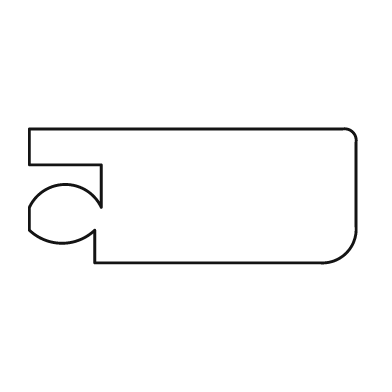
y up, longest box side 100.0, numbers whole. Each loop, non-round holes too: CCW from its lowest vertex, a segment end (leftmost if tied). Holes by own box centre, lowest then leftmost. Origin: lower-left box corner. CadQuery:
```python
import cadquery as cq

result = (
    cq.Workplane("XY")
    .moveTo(20.0, 0.0)
    .lineTo(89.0, 0.0)
    .threePointArc((97.0, 3.0), (100.0, 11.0))
    .lineTo(100.0, 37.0)
    .threePointArc((99.0, 40.0), (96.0, 41.0))
    .lineTo(0.0, 41.0)
    .lineTo(0.0, 30.0)
    .lineTo(22.0, 30.0)
    .lineTo(22.0, 17.0)
    .threePointArc((11.0, 24.0), (0.0, 17.0))
    .lineTo(0.0, 10.0)
    .threePointArc((10.0, 6.0), (20.0, 10.0))
    .close()
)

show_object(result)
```